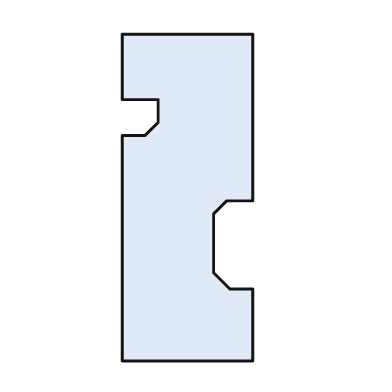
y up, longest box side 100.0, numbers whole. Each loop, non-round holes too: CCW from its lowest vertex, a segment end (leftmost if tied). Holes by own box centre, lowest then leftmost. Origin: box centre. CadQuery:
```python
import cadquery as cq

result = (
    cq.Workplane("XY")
    .moveTo(-20.0, -50.0)
    .lineTo(20.0, -50.0)
    .lineTo(20.0, -28.0)
    .lineTo(13.0, -28.0)
    .lineTo(8.0, -23.0)
    .lineTo(8.0, -5.0)
    .lineTo(12.0, -1.0)
    .lineTo(20.0, -1.0)
    .lineTo(20.0, 50.0)
    .lineTo(-20.0, 50.0)
    .lineTo(-20.0, 30.0)
    .lineTo(-9.0, 30.0)
    .lineTo(-9.0, 23.0)
    .lineTo(-13.0, 19.0)
    .lineTo(-20.0, 19.0)
    .close()
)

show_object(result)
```